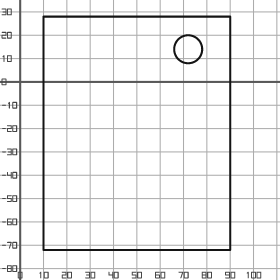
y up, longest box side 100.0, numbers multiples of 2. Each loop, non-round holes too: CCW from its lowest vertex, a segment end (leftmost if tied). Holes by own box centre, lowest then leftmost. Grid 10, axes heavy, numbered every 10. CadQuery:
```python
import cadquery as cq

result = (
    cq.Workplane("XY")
    .moveTo(10.0, -72.0)
    .lineTo(90.0, -72.0)
    .lineTo(90.0, 28.0)
    .lineTo(10.0, 28.0)
    .close()
    .moveTo(72.0, 14.0)
    .circle(6.0)
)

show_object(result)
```